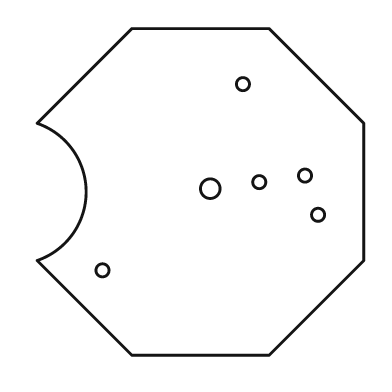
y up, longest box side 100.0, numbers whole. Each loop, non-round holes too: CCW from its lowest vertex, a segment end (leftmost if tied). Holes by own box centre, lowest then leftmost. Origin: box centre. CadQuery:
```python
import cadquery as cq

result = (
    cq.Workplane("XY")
    .moveTo(-21.0, -50.0)
    .lineTo(21.0, -50.0)
    .lineTo(50.0, -21.0)
    .lineTo(50.0, 21.0)
    .lineTo(21.0, 50.0)
    .lineTo(-21.0, 50.0)
    .lineTo(-50.0, 21.0)
    .threePointArc((-35.0, 0.0), (-50.0, -21.0))
    .close()
    .moveTo(-30.0, -24.0)
    .circle(2.0)
    .moveTo(36.0, -7.0)
    .circle(2.0)
    .moveTo(3.0, 1.0)
    .circle(3.0)
    .moveTo(18.0, 3.0)
    .circle(2.0)
    .moveTo(32.0, 5.0)
    .circle(2.0)
    .moveTo(13.0, 33.0)
    .circle(2.0)
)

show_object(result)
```